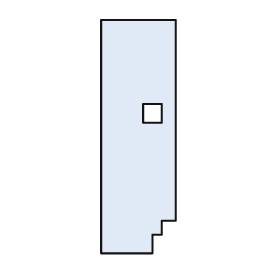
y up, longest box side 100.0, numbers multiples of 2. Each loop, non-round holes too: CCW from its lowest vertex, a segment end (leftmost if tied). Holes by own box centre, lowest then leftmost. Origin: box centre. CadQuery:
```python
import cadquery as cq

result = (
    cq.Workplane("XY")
    .moveTo(-16.0, -50.0)
    .lineTo(6.0, -50.0)
    .lineTo(6.0, -42.0)
    .lineTo(10.0, -42.0)
    .lineTo(10.0, -36.0)
    .lineTo(16.0, -36.0)
    .lineTo(16.0, 50.0)
    .lineTo(-16.0, 50.0)
    .close()
    .moveTo(2.0, 6.0)
    .lineTo(10.0, 6.0)
    .lineTo(10.0, 14.0)
    .lineTo(2.0, 14.0)
    .close()
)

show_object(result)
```